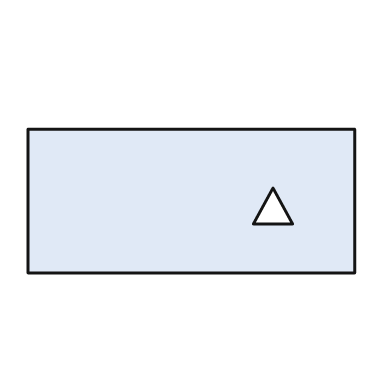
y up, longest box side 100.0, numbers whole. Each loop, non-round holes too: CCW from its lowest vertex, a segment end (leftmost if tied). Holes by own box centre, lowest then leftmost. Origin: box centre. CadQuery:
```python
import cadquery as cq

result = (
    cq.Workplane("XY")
    .moveTo(-50.0, -22.0)
    .lineTo(50.0, -22.0)
    .lineTo(50.0, 22.0)
    .lineTo(-50.0, 22.0)
    .close()
    .moveTo(19.0, -7.0)
    .lineTo(31.0, -7.0)
    .lineTo(25.0, 4.0)
    .close()
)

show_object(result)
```